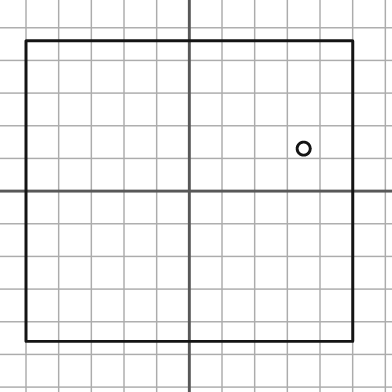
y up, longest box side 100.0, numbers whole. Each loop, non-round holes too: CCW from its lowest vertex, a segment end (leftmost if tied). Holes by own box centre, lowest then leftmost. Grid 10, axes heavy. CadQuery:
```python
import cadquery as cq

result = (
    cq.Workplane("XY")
    .moveTo(-50.0, -46.0)
    .lineTo(50.0, -46.0)
    .lineTo(50.0, 46.0)
    .lineTo(-50.0, 46.0)
    .close()
    .moveTo(35.0, 13.0)
    .circle(2.0)
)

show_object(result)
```